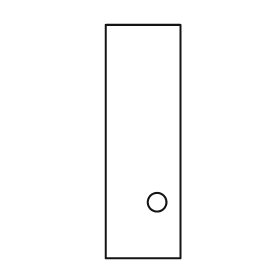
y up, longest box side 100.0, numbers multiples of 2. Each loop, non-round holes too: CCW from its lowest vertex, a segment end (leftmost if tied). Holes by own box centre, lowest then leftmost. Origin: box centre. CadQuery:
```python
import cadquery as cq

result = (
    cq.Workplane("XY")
    .moveTo(-16.0, -50.0)
    .lineTo(16.0, -50.0)
    .lineTo(16.0, 50.0)
    .lineTo(-16.0, 50.0)
    .close()
    .moveTo(6.0, -26.0)
    .circle(4.0)
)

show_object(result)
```